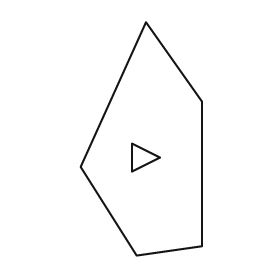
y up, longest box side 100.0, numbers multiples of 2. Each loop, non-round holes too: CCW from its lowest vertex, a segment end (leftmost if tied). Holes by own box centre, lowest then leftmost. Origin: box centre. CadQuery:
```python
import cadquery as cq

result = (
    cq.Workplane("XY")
    .moveTo(-2.0, -50.0)
    .lineTo(26.0, -46.0)
    .lineTo(26.0, 16.0)
    .lineTo(2.0, 50.0)
    .lineTo(-26.0, -12.0)
    .close()
    .moveTo(-4.0, -14.0)
    .lineTo(8.0, -8.0)
    .lineTo(-4.0, -2.0)
    .close()
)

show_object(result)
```